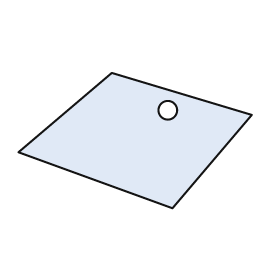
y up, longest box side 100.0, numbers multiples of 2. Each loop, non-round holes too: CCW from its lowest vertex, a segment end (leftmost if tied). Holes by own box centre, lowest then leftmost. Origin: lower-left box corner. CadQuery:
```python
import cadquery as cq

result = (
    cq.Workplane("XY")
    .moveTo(66.0, 0.0)
    .lineTo(100.0, 40.0)
    .lineTo(40.0, 58.0)
    .lineTo(0.0, 24.0)
    .close()
    .moveTo(64.0, 42.0)
    .circle(4.0)
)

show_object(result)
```